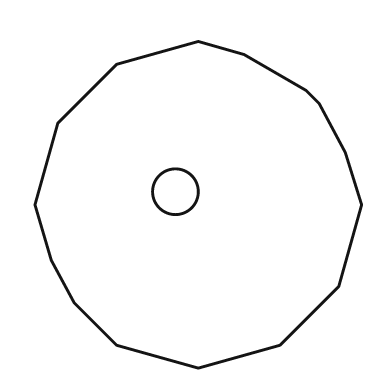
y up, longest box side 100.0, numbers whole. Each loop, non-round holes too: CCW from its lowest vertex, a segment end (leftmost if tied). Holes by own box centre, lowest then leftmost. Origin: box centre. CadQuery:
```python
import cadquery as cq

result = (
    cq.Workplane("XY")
    .moveTo(0.0, -50.0)
    .lineTo(25.0, -43.0)
    .lineTo(43.0, -25.0)
    .lineTo(50.0, 0.0)
    .lineTo(45.0, 16.0)
    .lineTo(37.0, 31.0)
    .lineTo(33.0, 35.0)
    .lineTo(14.0, 46.0)
    .lineTo(0.0, 50.0)
    .lineTo(-25.0, 43.0)
    .lineTo(-43.0, 25.0)
    .lineTo(-50.0, 0.0)
    .lineTo(-45.0, -17.0)
    .lineTo(-38.0, -30.0)
    .lineTo(-25.0, -43.0)
    .close()
    .moveTo(-7.0, 4.0)
    .circle(7.0)
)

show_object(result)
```